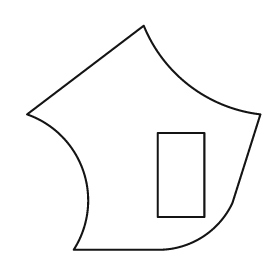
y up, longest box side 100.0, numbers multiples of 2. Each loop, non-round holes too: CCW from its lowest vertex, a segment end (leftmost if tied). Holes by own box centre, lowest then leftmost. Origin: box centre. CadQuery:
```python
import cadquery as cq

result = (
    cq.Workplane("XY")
    .moveTo(-30.0, -48.0)
    .lineTo(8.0, -48.0)
    .threePointArc((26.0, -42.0), (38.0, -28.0))
    .lineTo(50.0, 10.0)
    .threePointArc((20.0, 22.0), (0.0, 48.0))
    .lineTo(-50.0, 10.0)
    .threePointArc((-26.0, -14.0), (-30.0, -48.0))
    .close()
    .moveTo(6.0, -34.0)
    .lineTo(26.0, -34.0)
    .lineTo(26.0, 2.0)
    .lineTo(6.0, 2.0)
    .close()
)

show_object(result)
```